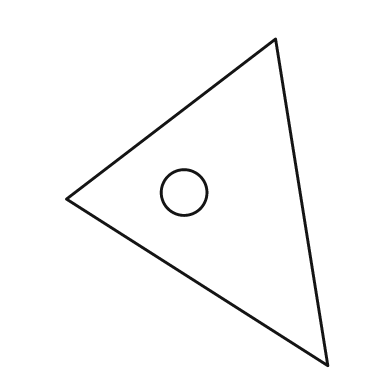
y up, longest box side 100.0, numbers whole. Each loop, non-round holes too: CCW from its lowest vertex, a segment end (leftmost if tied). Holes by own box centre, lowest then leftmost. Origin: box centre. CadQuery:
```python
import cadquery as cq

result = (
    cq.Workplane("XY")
    .moveTo(40.0, -50.0)
    .lineTo(24.0, 50.0)
    .lineTo(-40.0, 1.0)
    .close()
    .moveTo(-4.0, 3.0)
    .circle(7.0)
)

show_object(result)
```